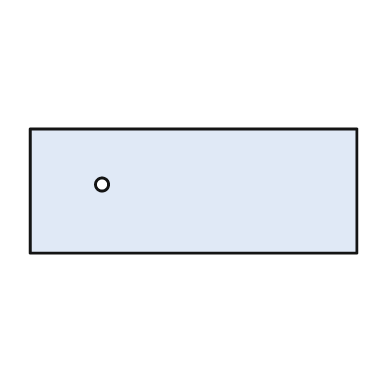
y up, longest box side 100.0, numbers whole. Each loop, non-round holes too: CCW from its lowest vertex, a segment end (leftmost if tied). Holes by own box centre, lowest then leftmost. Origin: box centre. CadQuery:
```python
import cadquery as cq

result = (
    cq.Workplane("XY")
    .moveTo(-50.0, -19.0)
    .lineTo(50.0, -19.0)
    .lineTo(50.0, 19.0)
    .lineTo(-50.0, 19.0)
    .close()
    .moveTo(-28.0, 2.0)
    .circle(2.0)
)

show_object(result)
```